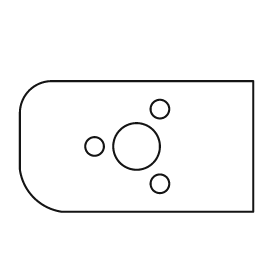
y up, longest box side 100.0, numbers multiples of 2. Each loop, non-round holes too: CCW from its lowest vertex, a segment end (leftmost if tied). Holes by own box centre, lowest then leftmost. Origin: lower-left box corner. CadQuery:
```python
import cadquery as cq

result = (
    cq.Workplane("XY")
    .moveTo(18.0, 0.0)
    .lineTo(100.0, 0.0)
    .lineTo(100.0, 56.0)
    .lineTo(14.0, 56.0)
    .threePointArc((4.0, 52.0), (0.0, 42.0))
    .lineTo(0.0, 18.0)
    .threePointArc((6.0, 6.0), (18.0, 0.0))
    .close()
    .moveTo(60.0, 12.0)
    .circle(4.0)
    .moveTo(32.0, 28.0)
    .circle(4.0)
    .moveTo(50.0, 28.0)
    .circle(10.0)
    .moveTo(60.0, 44.0)
    .circle(4.0)
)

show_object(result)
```